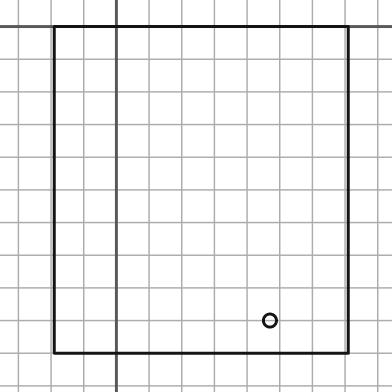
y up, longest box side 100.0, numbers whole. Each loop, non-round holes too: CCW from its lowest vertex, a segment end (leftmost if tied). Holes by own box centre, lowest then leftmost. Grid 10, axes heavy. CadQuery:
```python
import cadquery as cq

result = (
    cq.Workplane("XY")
    .moveTo(-19.0, -100.0)
    .lineTo(71.0, -100.0)
    .lineTo(71.0, 0.0)
    .lineTo(-19.0, 0.0)
    .close()
    .moveTo(47.0, -90.0)
    .circle(2.0)
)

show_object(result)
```